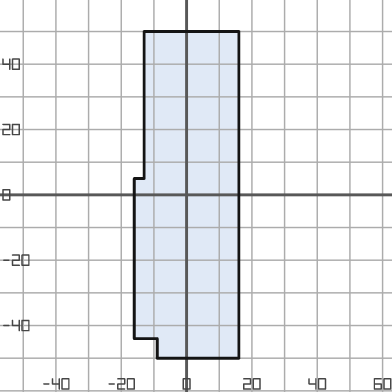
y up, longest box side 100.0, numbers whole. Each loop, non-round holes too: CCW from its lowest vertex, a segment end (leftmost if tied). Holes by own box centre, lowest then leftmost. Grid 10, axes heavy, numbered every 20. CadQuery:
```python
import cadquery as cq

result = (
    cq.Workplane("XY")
    .moveTo(-9.0, -50.0)
    .lineTo(16.0, -50.0)
    .lineTo(16.0, 50.0)
    .lineTo(-13.0, 50.0)
    .lineTo(-13.0, 5.0)
    .lineTo(-16.0, 5.0)
    .lineTo(-16.0, -44.0)
    .lineTo(-9.0, -44.0)
    .close()
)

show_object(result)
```